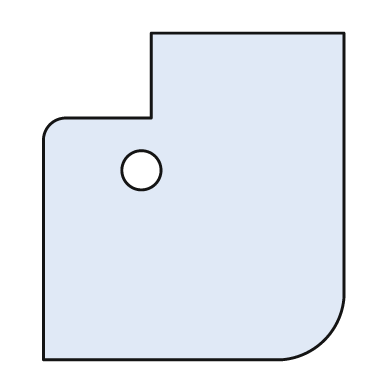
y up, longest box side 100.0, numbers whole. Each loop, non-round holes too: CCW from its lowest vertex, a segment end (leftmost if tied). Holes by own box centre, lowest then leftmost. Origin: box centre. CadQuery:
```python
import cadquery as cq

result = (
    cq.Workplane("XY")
    .moveTo(-46.0, -50.0)
    .lineTo(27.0, -50.0)
    .threePointArc((40.0, -44.0), (46.0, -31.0))
    .lineTo(46.0, 50.0)
    .lineTo(-13.0, 50.0)
    .lineTo(-13.0, 24.0)
    .lineTo(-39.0, 24.0)
    .threePointArc((-44.0, 22.0), (-46.0, 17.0))
    .close()
    .moveTo(-16.0, 8.0)
    .circle(6.0)
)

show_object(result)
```